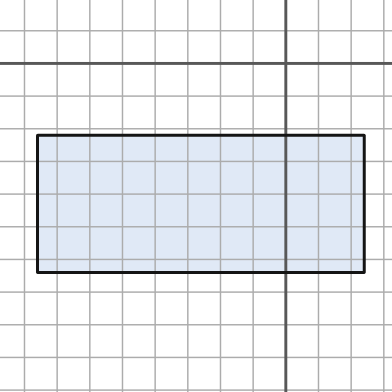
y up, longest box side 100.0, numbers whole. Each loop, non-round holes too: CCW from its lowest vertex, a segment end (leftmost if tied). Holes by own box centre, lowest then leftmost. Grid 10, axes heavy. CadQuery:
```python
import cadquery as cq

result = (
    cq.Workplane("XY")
    .moveTo(-76.0, -64.0)
    .lineTo(24.0, -64.0)
    .lineTo(24.0, -22.0)
    .lineTo(-76.0, -22.0)
    .close()
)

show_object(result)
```